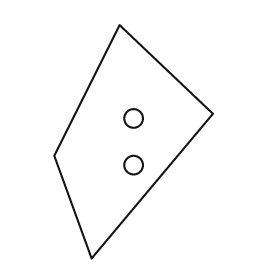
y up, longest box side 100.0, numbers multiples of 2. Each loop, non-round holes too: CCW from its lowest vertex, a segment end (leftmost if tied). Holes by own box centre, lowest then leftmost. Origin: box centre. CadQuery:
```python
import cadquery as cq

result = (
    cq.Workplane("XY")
    .moveTo(-18.0, -50.0)
    .lineTo(34.0, 12.0)
    .lineTo(-6.0, 50.0)
    .lineTo(-34.0, -6.0)
    .close()
    .moveTo(0.0, -10.0)
    .circle(4.0)
    .moveTo(0.0, 10.0)
    .circle(4.0)
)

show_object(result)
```